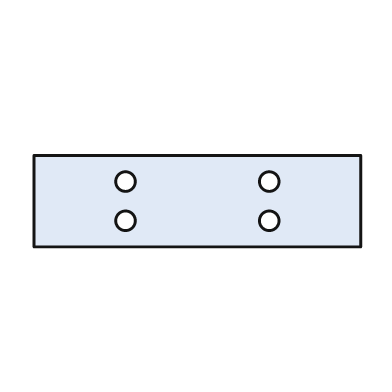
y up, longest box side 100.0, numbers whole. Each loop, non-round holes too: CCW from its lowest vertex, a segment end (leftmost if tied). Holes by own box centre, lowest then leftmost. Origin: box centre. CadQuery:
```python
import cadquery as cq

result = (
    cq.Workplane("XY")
    .moveTo(-50.0, -14.0)
    .lineTo(50.0, -14.0)
    .lineTo(50.0, 14.0)
    .lineTo(-50.0, 14.0)
    .close()
    .moveTo(-22.0, -6.0)
    .circle(3.0)
    .moveTo(22.0, -6.0)
    .circle(3.0)
    .moveTo(-22.0, 6.0)
    .circle(3.0)
    .moveTo(22.0, 6.0)
    .circle(3.0)
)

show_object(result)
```